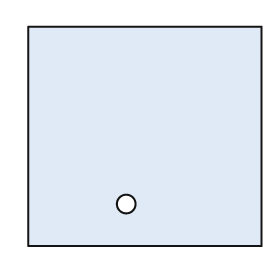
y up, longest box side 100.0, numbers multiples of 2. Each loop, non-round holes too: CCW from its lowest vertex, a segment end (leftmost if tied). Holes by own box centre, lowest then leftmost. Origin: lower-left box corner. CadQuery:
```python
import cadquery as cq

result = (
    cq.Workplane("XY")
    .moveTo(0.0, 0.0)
    .lineTo(100.0, 0.0)
    .lineTo(100.0, 94.0)
    .lineTo(0.0, 94.0)
    .close()
    .moveTo(42.0, 18.0)
    .circle(4.0)
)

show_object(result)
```